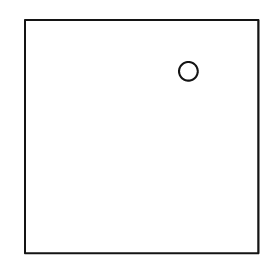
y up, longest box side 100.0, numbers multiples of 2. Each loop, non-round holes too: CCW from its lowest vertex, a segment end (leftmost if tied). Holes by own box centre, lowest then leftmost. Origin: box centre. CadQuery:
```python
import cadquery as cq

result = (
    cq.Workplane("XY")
    .moveTo(-50.0, -50.0)
    .lineTo(50.0, -50.0)
    .lineTo(50.0, 50.0)
    .lineTo(-50.0, 50.0)
    .close()
    .moveTo(20.0, 28.0)
    .circle(4.0)
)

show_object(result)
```